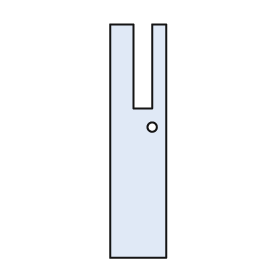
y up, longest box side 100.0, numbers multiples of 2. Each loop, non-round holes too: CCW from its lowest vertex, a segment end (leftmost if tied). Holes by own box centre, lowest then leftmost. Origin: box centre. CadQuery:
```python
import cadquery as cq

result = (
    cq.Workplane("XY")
    .moveTo(-12.0, -50.0)
    .lineTo(12.0, -50.0)
    .lineTo(12.0, 50.0)
    .lineTo(6.0, 50.0)
    .lineTo(6.0, 14.0)
    .lineTo(-2.0, 14.0)
    .lineTo(-2.0, 50.0)
    .lineTo(-12.0, 50.0)
    .close()
    .moveTo(6.0, 6.0)
    .circle(2.0)
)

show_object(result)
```